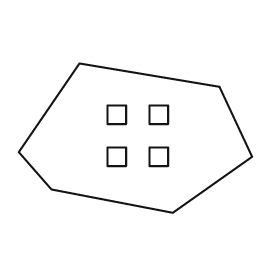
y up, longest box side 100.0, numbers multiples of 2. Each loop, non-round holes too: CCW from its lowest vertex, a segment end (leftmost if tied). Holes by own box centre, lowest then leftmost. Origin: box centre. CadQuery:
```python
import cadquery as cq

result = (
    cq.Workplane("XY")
    .moveTo(16.0, -32.0)
    .lineTo(50.0, -8.0)
    .lineTo(36.0, 22.0)
    .lineTo(-24.0, 32.0)
    .lineTo(-50.0, -6.0)
    .lineTo(-36.0, -22.0)
    .close()
    .moveTo(-12.0, -12.0)
    .lineTo(-4.0, -12.0)
    .lineTo(-4.0, -4.0)
    .lineTo(-12.0, -4.0)
    .close()
    .moveTo(6.0, -12.0)
    .lineTo(14.0, -12.0)
    .lineTo(14.0, -4.0)
    .lineTo(6.0, -4.0)
    .close()
    .moveTo(-12.0, 6.0)
    .lineTo(-4.0, 6.0)
    .lineTo(-4.0, 14.0)
    .lineTo(-12.0, 14.0)
    .close()
    .moveTo(6.0, 6.0)
    .lineTo(14.0, 6.0)
    .lineTo(14.0, 14.0)
    .lineTo(6.0, 14.0)
    .close()
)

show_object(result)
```